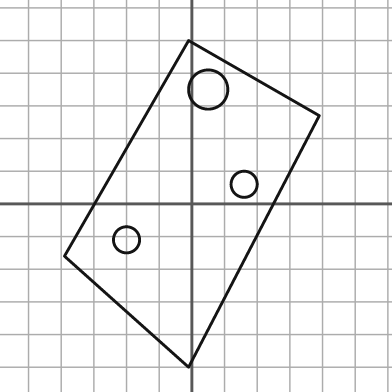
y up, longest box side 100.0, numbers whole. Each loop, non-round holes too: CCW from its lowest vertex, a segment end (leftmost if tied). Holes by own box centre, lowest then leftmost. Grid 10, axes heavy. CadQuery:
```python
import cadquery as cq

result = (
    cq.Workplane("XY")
    .moveTo(-1.0, -50.0)
    .lineTo(39.0, 27.0)
    .lineTo(-1.0, 50.0)
    .lineTo(-39.0, -16.0)
    .close()
    .moveTo(-20.0, -11.0)
    .circle(4.0)
    .moveTo(16.0, 6.0)
    .circle(4.0)
    .moveTo(5.0, 35.0)
    .circle(6.0)
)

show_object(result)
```